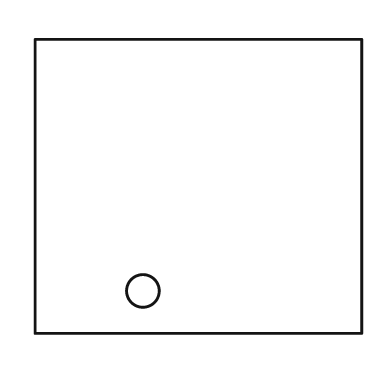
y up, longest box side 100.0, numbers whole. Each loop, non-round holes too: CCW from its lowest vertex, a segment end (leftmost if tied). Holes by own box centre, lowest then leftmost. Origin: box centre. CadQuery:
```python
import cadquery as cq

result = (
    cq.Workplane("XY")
    .moveTo(-50.0, -45.0)
    .lineTo(50.0, -45.0)
    .lineTo(50.0, 45.0)
    .lineTo(-50.0, 45.0)
    .close()
    .moveTo(-17.0, -32.0)
    .circle(5.0)
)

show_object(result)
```